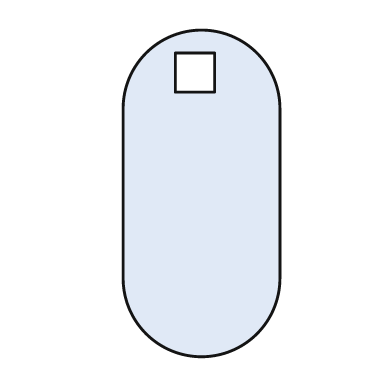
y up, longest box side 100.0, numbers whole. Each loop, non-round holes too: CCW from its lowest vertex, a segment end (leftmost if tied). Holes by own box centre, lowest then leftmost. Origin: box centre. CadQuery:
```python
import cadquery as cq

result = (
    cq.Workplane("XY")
    .moveTo(-24.0, -26.0)
    .threePointArc((0.0, -50.0), (24.0, -26.0))
    .lineTo(24.0, 26.0)
    .threePointArc((0.0, 50.0), (-24.0, 26.0))
    .close()
    .moveTo(-8.0, 31.0)
    .lineTo(4.0, 31.0)
    .lineTo(4.0, 43.0)
    .lineTo(-8.0, 43.0)
    .close()
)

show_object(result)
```